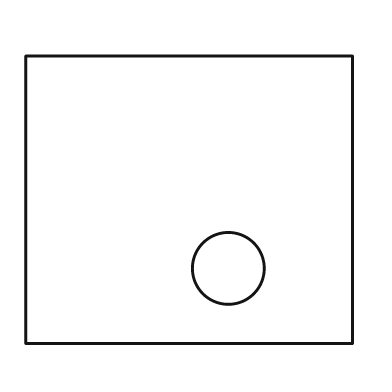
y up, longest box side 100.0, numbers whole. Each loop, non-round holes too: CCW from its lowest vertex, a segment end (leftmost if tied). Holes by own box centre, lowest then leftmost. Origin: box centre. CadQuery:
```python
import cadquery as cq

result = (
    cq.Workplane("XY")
    .moveTo(-50.0, -44.0)
    .lineTo(50.0, -44.0)
    .lineTo(50.0, 44.0)
    .lineTo(-50.0, 44.0)
    .close()
    .moveTo(12.0, -21.0)
    .circle(11.0)
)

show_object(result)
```